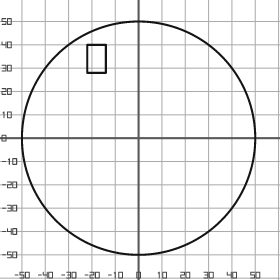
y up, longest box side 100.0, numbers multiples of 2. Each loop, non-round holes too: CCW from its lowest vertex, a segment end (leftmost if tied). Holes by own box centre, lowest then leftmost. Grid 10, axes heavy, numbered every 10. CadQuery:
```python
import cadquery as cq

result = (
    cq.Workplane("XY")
    .moveTo(0.0, 0.0)
    .circle(50.0)
    .moveTo(-22.0, 28.0)
    .lineTo(-14.0, 28.0)
    .lineTo(-14.0, 40.0)
    .lineTo(-22.0, 40.0)
    .close()
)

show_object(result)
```